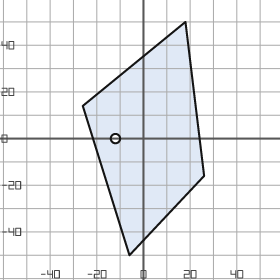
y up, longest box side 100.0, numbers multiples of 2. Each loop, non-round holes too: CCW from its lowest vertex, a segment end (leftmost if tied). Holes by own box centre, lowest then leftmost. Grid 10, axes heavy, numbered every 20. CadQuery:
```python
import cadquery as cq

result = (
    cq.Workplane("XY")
    .moveTo(-6.0, -50.0)
    .lineTo(26.0, -16.0)
    .lineTo(18.0, 50.0)
    .lineTo(-26.0, 14.0)
    .close()
    .moveTo(-12.0, 0.0)
    .circle(2.0)
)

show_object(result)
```